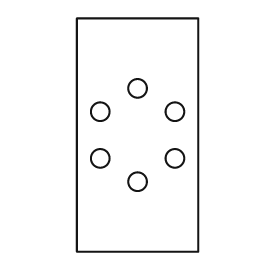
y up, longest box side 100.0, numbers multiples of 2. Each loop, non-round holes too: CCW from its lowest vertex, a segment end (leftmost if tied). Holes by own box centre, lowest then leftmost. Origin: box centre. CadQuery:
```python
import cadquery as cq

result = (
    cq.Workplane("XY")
    .moveTo(-26.0, -50.0)
    .lineTo(26.0, -50.0)
    .lineTo(26.0, 50.0)
    .lineTo(-26.0, 50.0)
    .close()
    .moveTo(0.0, -20.0)
    .circle(4.0)
    .moveTo(-16.0, -10.0)
    .circle(4.0)
    .moveTo(16.0, -10.0)
    .circle(4.0)
    .moveTo(-16.0, 10.0)
    .circle(4.0)
    .moveTo(16.0, 10.0)
    .circle(4.0)
    .moveTo(0.0, 20.0)
    .circle(4.0)
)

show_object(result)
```